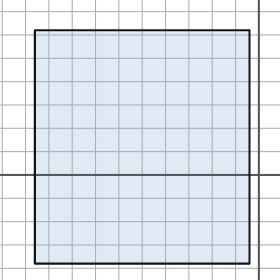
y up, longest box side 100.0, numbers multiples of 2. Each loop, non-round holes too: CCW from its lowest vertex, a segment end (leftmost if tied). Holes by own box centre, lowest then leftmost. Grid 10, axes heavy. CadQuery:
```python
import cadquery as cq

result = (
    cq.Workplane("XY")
    .moveTo(-96.0, -38.0)
    .lineTo(-4.0, -38.0)
    .lineTo(-4.0, 62.0)
    .lineTo(-96.0, 62.0)
    .close()
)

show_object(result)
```